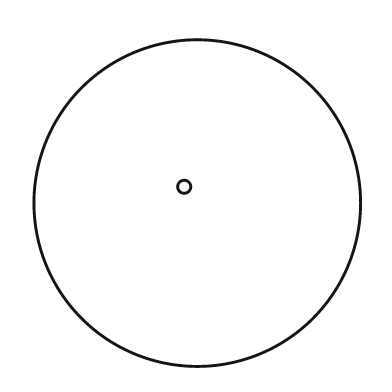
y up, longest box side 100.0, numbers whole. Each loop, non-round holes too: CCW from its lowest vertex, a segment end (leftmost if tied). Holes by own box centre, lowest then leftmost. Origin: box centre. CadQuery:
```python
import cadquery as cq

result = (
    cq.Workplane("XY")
    .moveTo(0.0, 0.0)
    .circle(50.0)
    .moveTo(-4.0, 5.0)
    .circle(2.0)
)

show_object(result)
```